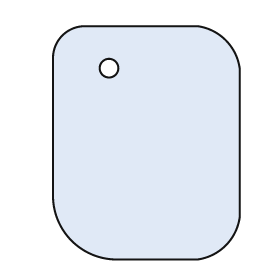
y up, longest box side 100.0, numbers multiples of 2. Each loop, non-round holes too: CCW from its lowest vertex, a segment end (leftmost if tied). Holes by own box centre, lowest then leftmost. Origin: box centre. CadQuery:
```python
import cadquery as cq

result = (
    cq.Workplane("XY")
    .moveTo(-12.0, -50.0)
    .lineTo(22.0, -50.0)
    .threePointArc((34.0, -44.0), (40.0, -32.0))
    .lineTo(40.0, 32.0)
    .threePointArc((34.0, 44.0), (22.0, 50.0))
    .lineTo(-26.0, 50.0)
    .threePointArc((-36.0, 46.0), (-40.0, 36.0))
    .lineTo(-40.0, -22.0)
    .threePointArc((-32.0, -42.0), (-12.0, -50.0))
    .close()
    .moveTo(-16.0, 32.0)
    .circle(4.0)
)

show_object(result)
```